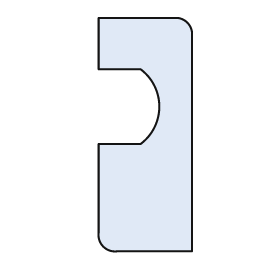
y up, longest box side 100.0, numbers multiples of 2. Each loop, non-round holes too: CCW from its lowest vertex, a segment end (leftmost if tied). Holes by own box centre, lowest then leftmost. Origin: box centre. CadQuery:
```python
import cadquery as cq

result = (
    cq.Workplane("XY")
    .moveTo(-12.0, -50.0)
    .lineTo(20.0, -50.0)
    .lineTo(20.0, 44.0)
    .threePointArc((18.0, 48.0), (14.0, 50.0))
    .lineTo(-20.0, 50.0)
    .lineTo(-20.0, 28.0)
    .lineTo(-2.0, 28.0)
    .threePointArc((6.0, 12.0), (-2.0, -4.0))
    .lineTo(-20.0, -4.0)
    .lineTo(-20.0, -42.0)
    .threePointArc((-18.0, -48.0), (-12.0, -50.0))
    .close()
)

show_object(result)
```